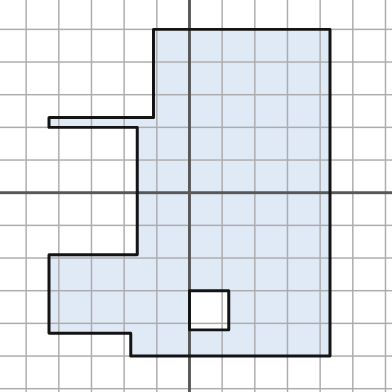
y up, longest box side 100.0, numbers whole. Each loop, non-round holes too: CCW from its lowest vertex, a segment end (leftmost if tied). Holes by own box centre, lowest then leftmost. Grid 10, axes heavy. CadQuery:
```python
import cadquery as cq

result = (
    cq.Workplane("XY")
    .moveTo(-18.0, -50.0)
    .lineTo(43.0, -50.0)
    .lineTo(43.0, 50.0)
    .lineTo(-11.0, 50.0)
    .lineTo(-11.0, 23.0)
    .lineTo(-43.0, 23.0)
    .lineTo(-43.0, 20.0)
    .lineTo(-16.0, 20.0)
    .lineTo(-16.0, -19.0)
    .lineTo(-43.0, -19.0)
    .lineTo(-43.0, -43.0)
    .lineTo(-18.0, -43.0)
    .close()
    .moveTo(0.0, -42.0)
    .lineTo(12.0, -42.0)
    .lineTo(12.0, -30.0)
    .lineTo(0.0, -30.0)
    .close()
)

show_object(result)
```